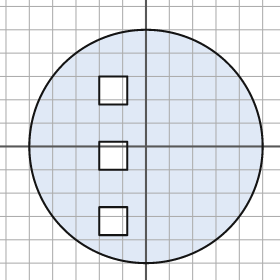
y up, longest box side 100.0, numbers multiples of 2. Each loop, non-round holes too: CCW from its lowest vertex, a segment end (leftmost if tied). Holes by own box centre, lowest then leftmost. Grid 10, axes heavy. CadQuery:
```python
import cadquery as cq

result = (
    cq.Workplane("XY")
    .moveTo(0.0, 0.0)
    .circle(50.0)
    .moveTo(-20.0, -38.0)
    .lineTo(-8.0, -38.0)
    .lineTo(-8.0, -26.0)
    .lineTo(-20.0, -26.0)
    .close()
    .moveTo(-20.0, -10.0)
    .lineTo(-8.0, -10.0)
    .lineTo(-8.0, 2.0)
    .lineTo(-20.0, 2.0)
    .close()
    .moveTo(-20.0, 18.0)
    .lineTo(-8.0, 18.0)
    .lineTo(-8.0, 30.0)
    .lineTo(-20.0, 30.0)
    .close()
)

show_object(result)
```